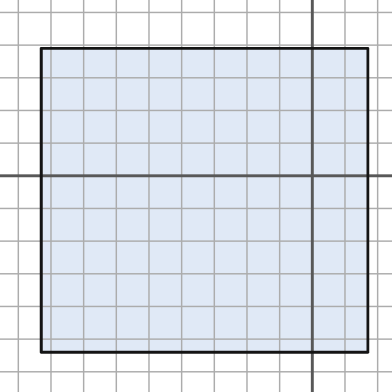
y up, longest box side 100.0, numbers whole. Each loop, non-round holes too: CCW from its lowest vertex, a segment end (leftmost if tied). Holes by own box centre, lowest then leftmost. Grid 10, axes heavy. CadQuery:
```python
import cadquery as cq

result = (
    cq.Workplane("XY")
    .moveTo(-83.0, -54.0)
    .lineTo(17.0, -54.0)
    .lineTo(17.0, 39.0)
    .lineTo(-83.0, 39.0)
    .close()
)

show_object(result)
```